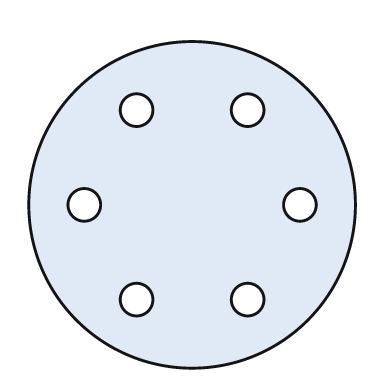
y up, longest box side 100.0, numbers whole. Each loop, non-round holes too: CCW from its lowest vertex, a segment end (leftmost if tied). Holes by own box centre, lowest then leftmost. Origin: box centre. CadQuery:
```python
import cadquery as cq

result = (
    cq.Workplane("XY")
    .moveTo(0.0, 0.0)
    .circle(50.0)
    .moveTo(-17.0, -29.0)
    .circle(5.0)
    .moveTo(17.0, -29.0)
    .circle(5.0)
    .moveTo(-33.0, 0.0)
    .circle(5.0)
    .moveTo(33.0, 0.0)
    .circle(5.0)
    .moveTo(-17.0, 29.0)
    .circle(5.0)
    .moveTo(17.0, 29.0)
    .circle(5.0)
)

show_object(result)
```